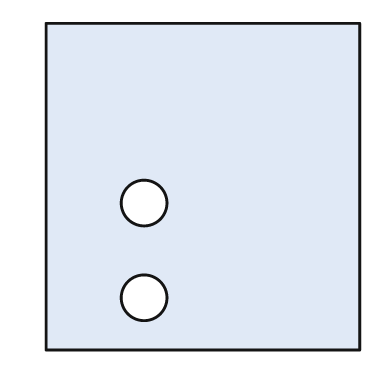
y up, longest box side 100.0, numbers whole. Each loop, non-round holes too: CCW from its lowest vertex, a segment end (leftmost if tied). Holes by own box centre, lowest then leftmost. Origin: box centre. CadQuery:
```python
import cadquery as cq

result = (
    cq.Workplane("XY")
    .moveTo(-48.0, -50.0)
    .lineTo(48.0, -50.0)
    .lineTo(48.0, 50.0)
    .lineTo(-48.0, 50.0)
    .close()
    .moveTo(-18.0, -34.0)
    .circle(7.0)
    .moveTo(-18.0, -5.0)
    .circle(7.0)
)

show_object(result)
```